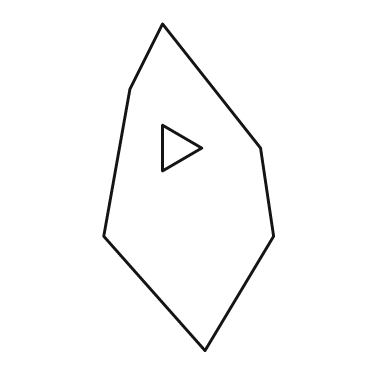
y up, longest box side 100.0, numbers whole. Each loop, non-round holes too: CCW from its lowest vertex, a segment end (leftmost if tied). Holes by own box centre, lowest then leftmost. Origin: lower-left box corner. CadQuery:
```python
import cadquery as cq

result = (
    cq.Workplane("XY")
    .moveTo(31.0, 0.0)
    .lineTo(52.0, 35.0)
    .lineTo(48.0, 62.0)
    .lineTo(18.0, 100.0)
    .lineTo(8.0, 80.0)
    .lineTo(0.0, 35.0)
    .close()
    .moveTo(18.0, 55.0)
    .lineTo(30.0, 62.0)
    .lineTo(18.0, 69.0)
    .close()
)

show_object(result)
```